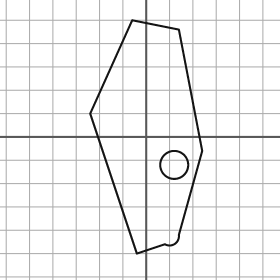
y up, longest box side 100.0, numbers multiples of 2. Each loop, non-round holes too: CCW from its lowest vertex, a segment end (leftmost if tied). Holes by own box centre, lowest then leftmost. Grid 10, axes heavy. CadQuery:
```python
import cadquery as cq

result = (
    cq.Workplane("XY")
    .moveTo(-4.0, -50.0)
    .lineTo(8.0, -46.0)
    .threePointArc((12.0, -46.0), (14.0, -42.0))
    .lineTo(24.0, -6.0)
    .lineTo(14.0, 46.0)
    .lineTo(-6.0, 50.0)
    .lineTo(-24.0, 10.0)
    .close()
    .moveTo(12.0, -12.0)
    .circle(6.0)
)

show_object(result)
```